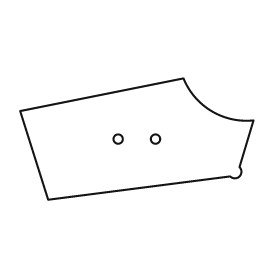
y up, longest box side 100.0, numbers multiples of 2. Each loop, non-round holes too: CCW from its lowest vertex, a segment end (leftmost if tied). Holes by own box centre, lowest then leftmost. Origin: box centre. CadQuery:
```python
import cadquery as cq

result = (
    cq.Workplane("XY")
    .moveTo(-38.0, -26.0)
    .lineTo(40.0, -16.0)
    .threePointArc((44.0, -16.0), (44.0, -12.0))
    .lineTo(50.0, 8.0)
    .threePointArc((32.0, 12.0), (20.0, 26.0))
    .lineTo(-50.0, 12.0)
    .close()
    .moveTo(-8.0, 0.0)
    .circle(2.0)
    .moveTo(8.0, 0.0)
    .circle(2.0)
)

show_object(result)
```